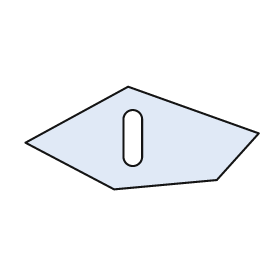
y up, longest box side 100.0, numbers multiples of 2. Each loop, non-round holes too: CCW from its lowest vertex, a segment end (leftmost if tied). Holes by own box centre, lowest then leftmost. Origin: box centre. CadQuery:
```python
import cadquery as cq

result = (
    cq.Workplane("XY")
    .moveTo(-12.0, -22.0)
    .lineTo(32.0, -18.0)
    .lineTo(50.0, 2.0)
    .lineTo(-6.0, 22.0)
    .lineTo(-50.0, -2.0)
    .close()
    .moveTo(-8.0, -8.0)
    .threePointArc((-4.0, -12.0), (0.0, -8.0))
    .lineTo(0.0, 8.0)
    .threePointArc((-4.0, 12.0), (-8.0, 8.0))
    .close()
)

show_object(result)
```